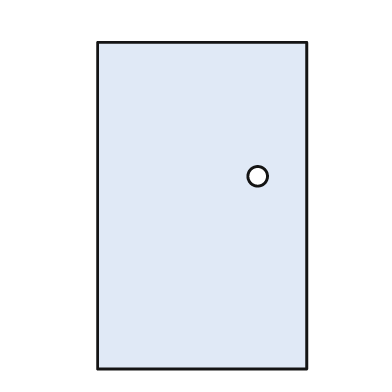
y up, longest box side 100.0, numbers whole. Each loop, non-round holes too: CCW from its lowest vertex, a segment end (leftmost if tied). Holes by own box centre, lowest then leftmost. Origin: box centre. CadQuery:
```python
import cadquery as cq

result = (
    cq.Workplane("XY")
    .moveTo(-32.0, -50.0)
    .lineTo(32.0, -50.0)
    .lineTo(32.0, 50.0)
    .lineTo(-32.0, 50.0)
    .close()
    .moveTo(17.0, 9.0)
    .circle(3.0)
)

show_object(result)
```